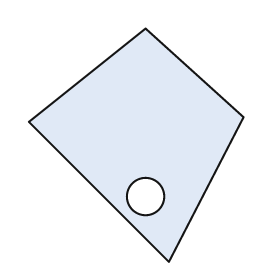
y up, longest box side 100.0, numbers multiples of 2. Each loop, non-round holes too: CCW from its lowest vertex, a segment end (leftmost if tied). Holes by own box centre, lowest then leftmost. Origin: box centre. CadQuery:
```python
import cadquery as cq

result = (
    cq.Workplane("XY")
    .moveTo(14.0, -50.0)
    .lineTo(46.0, 12.0)
    .lineTo(4.0, 50.0)
    .lineTo(-46.0, 10.0)
    .close()
    .moveTo(4.0, -22.0)
    .circle(8.0)
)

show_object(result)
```